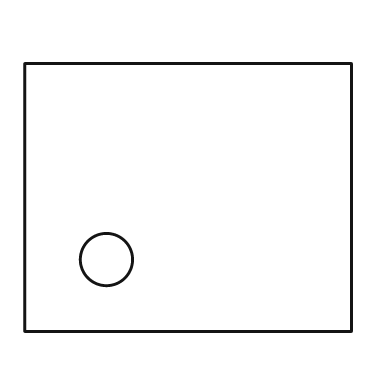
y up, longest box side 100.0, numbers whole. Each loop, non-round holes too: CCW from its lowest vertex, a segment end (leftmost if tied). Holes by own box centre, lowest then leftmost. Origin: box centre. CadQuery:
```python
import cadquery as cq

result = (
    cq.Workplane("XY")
    .moveTo(-50.0, -41.0)
    .lineTo(50.0, -41.0)
    .lineTo(50.0, 41.0)
    .lineTo(-50.0, 41.0)
    .close()
    .moveTo(-25.0, -19.0)
    .circle(8.0)
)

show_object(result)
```